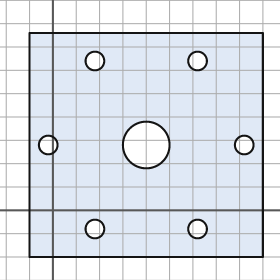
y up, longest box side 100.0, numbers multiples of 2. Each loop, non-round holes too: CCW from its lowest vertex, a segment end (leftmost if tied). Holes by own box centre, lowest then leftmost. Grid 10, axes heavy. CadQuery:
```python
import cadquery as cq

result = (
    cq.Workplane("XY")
    .moveTo(-10.0, -20.0)
    .lineTo(90.0, -20.0)
    .lineTo(90.0, 76.0)
    .lineTo(-10.0, 76.0)
    .close()
    .moveTo(18.0, -8.0)
    .circle(4.0)
    .moveTo(62.0, -8.0)
    .circle(4.0)
    .moveTo(-2.0, 28.0)
    .circle(4.0)
    .moveTo(40.0, 28.0)
    .circle(10.0)
    .moveTo(82.0, 28.0)
    .circle(4.0)
    .moveTo(18.0, 64.0)
    .circle(4.0)
    .moveTo(62.0, 64.0)
    .circle(4.0)
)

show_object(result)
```